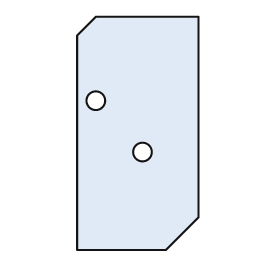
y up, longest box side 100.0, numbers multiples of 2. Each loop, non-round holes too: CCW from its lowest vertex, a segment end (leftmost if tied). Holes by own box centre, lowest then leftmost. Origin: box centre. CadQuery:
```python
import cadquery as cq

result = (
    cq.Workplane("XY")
    .moveTo(-26.0, -50.0)
    .lineTo(12.0, -50.0)
    .lineTo(26.0, -36.0)
    .lineTo(26.0, 50.0)
    .lineTo(-18.0, 50.0)
    .lineTo(-26.0, 42.0)
    .close()
    .moveTo(2.0, -8.0)
    .circle(4.0)
    .moveTo(-18.0, 14.0)
    .circle(4.0)
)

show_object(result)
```